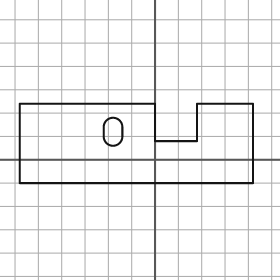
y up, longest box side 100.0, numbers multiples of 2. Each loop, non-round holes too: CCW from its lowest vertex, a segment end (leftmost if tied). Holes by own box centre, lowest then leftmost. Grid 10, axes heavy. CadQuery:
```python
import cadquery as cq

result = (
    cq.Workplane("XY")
    .moveTo(-58.0, -10.0)
    .lineTo(42.0, -10.0)
    .lineTo(42.0, 24.0)
    .lineTo(18.0, 24.0)
    .lineTo(18.0, 8.0)
    .lineTo(0.0, 8.0)
    .lineTo(0.0, 24.0)
    .lineTo(-58.0, 24.0)
    .close()
    .moveTo(-22.0, 10.0)
    .threePointArc((-18.0, 6.0), (-14.0, 10.0))
    .lineTo(-14.0, 14.0)
    .threePointArc((-18.0, 18.0), (-22.0, 14.0))
    .close()
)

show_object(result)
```